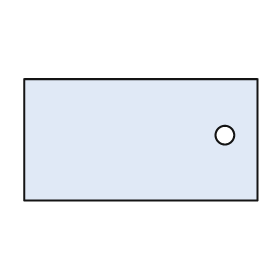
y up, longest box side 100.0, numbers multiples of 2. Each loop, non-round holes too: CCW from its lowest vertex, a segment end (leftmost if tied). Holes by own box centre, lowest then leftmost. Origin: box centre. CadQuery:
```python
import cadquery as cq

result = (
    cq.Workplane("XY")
    .moveTo(-50.0, -26.0)
    .lineTo(50.0, -26.0)
    .lineTo(50.0, 26.0)
    .lineTo(-50.0, 26.0)
    .close()
    .moveTo(36.0, 2.0)
    .circle(4.0)
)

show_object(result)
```